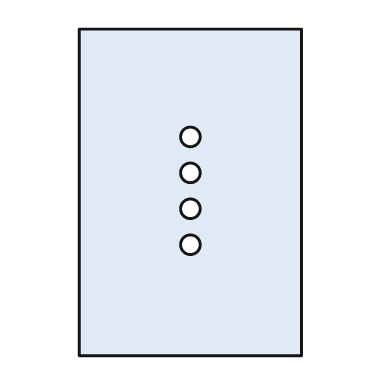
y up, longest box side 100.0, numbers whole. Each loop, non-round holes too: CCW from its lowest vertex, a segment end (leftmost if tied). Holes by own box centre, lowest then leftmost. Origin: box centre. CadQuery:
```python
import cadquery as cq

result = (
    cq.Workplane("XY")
    .moveTo(-34.0, -50.0)
    .lineTo(34.0, -50.0)
    .lineTo(34.0, 50.0)
    .lineTo(-34.0, 50.0)
    .close()
    .moveTo(0.0, -16.0)
    .circle(3.0)
    .moveTo(0.0, -5.0)
    .circle(3.0)
    .moveTo(0.0, 6.0)
    .circle(3.0)
    .moveTo(0.0, 17.0)
    .circle(3.0)
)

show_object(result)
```